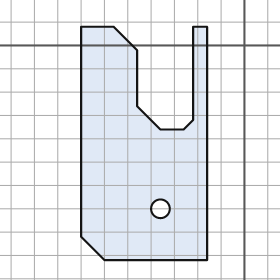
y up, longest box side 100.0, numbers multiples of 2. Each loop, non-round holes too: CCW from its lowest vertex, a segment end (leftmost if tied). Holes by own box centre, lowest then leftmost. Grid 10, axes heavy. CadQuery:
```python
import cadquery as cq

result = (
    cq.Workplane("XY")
    .moveTo(-60.0, -92.0)
    .lineTo(-16.0, -92.0)
    .lineTo(-16.0, 8.0)
    .lineTo(-22.0, 8.0)
    .lineTo(-22.0, -32.0)
    .lineTo(-26.0, -36.0)
    .lineTo(-36.0, -36.0)
    .lineTo(-46.0, -26.0)
    .lineTo(-46.0, -2.0)
    .lineTo(-56.0, 8.0)
    .lineTo(-70.0, 8.0)
    .lineTo(-70.0, -82.0)
    .close()
    .moveTo(-36.0, -70.0)
    .circle(4.0)
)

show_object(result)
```